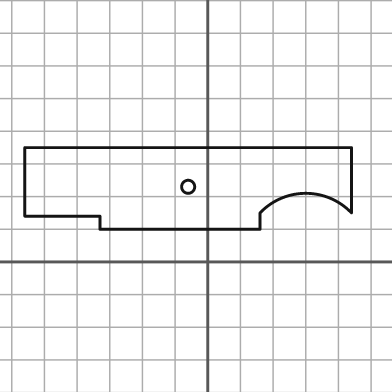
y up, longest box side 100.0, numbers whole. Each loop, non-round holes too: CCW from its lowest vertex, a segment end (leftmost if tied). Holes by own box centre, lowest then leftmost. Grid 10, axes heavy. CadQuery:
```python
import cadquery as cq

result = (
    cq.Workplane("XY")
    .moveTo(-33.0, 10.0)
    .lineTo(16.0, 10.0)
    .lineTo(16.0, 15.0)
    .threePointArc((30.0, 21.0), (44.0, 15.0))
    .lineTo(44.0, 35.0)
    .lineTo(-56.0, 35.0)
    .lineTo(-56.0, 14.0)
    .lineTo(-33.0, 14.0)
    .close()
    .moveTo(-6.0, 23.0)
    .circle(2.0)
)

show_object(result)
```